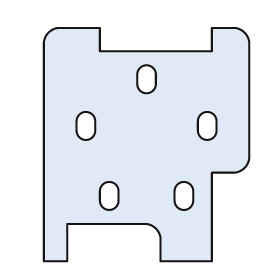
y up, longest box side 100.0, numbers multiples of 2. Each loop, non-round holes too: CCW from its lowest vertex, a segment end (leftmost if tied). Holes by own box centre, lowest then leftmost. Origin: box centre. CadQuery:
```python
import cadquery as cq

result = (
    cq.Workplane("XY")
    .moveTo(-44.0, -50.0)
    .lineTo(-34.0, -50.0)
    .lineTo(-34.0, -34.0)
    .lineTo(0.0, -34.0)
    .threePointArc((4.0, -36.0), (6.0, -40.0))
    .lineTo(6.0, -50.0)
    .lineTo(28.0, -50.0)
    .lineTo(28.0, -12.0)
    .lineTo(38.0, -12.0)
    .threePointArc((42.0, -10.0), (44.0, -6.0))
    .lineTo(44.0, 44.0)
    .threePointArc((42.0, 48.0), (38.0, 50.0))
    .lineTo(28.0, 50.0)
    .lineTo(28.0, 40.0)
    .lineTo(-20.0, 40.0)
    .lineTo(-20.0, 50.0)
    .lineTo(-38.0, 50.0)
    .threePointArc((-42.0, 48.0), (-44.0, 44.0))
    .close()
    .moveTo(-20.0, -24.0)
    .threePointArc((-16.0, -28.0), (-12.0, -24.0))
    .lineTo(-12.0, -20.0)
    .threePointArc((-16.0, -16.0), (-20.0, -20.0))
    .close()
    .moveTo(12.0, -24.0)
    .threePointArc((16.0, -28.0), (20.0, -24.0))
    .lineTo(20.0, -20.0)
    .threePointArc((16.0, -16.0), (12.0, -20.0))
    .close()
    .moveTo(-30.0, 6.0)
    .threePointArc((-26.0, 2.0), (-22.0, 6.0))
    .lineTo(-22.0, 10.0)
    .threePointArc((-26.0, 14.0), (-30.0, 10.0))
    .close()
    .moveTo(22.0, 6.0)
    .threePointArc((26.0, 2.0), (30.0, 6.0))
    .lineTo(30.0, 10.0)
    .threePointArc((26.0, 14.0), (22.0, 10.0))
    .close()
    .moveTo(-4.0, 26.0)
    .threePointArc((0.0, 22.0), (4.0, 26.0))
    .lineTo(4.0, 30.0)
    .threePointArc((0.0, 34.0), (-4.0, 30.0))
    .close()
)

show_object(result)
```